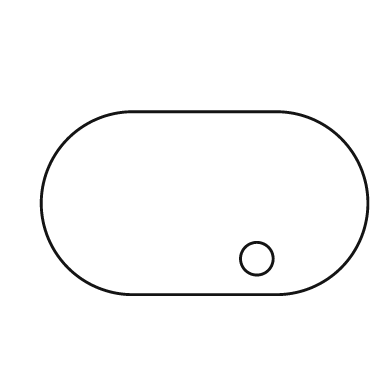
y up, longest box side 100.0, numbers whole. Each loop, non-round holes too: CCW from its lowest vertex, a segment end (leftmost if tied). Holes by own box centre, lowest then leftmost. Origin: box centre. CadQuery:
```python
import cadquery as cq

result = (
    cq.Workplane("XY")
    .moveTo(-22.0, -28.0)
    .lineTo(22.0, -28.0)
    .threePointArc((50.0, 0.0), (22.0, 28.0))
    .lineTo(-22.0, 28.0)
    .threePointArc((-50.0, 0.0), (-22.0, -28.0))
    .close()
    .moveTo(16.0, -17.0)
    .circle(5.0)
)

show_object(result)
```